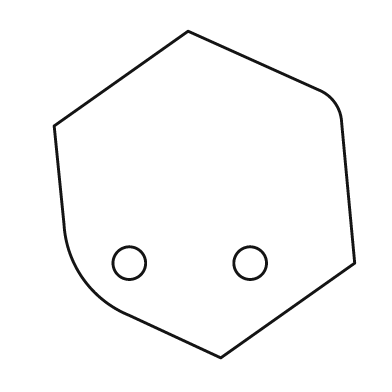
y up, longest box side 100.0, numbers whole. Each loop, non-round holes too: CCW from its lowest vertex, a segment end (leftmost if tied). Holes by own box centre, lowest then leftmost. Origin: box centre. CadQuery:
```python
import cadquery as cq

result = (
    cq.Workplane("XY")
    .moveTo(5.0, -50.0)
    .lineTo(46.0, -21.0)
    .lineTo(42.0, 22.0)
    .threePointArc((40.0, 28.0), (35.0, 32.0))
    .lineTo(-5.0, 50.0)
    .lineTo(-46.0, 21.0)
    .lineTo(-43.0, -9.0)
    .threePointArc((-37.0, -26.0), (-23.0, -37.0))
    .close()
    .moveTo(-23.0, -21.0)
    .circle(5.0)
    .moveTo(14.0, -21.0)
    .circle(5.0)
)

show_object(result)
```